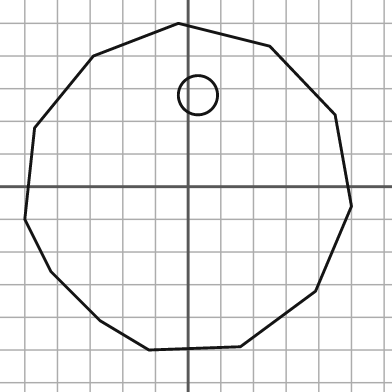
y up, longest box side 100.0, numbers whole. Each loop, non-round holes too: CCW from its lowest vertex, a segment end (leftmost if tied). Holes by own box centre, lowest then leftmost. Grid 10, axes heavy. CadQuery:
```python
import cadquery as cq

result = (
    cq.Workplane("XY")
    .moveTo(-12.0, -50.0)
    .lineTo(16.0, -49.0)
    .lineTo(39.0, -32.0)
    .lineTo(50.0, -6.0)
    .lineTo(45.0, 22.0)
    .lineTo(25.0, 43.0)
    .lineTo(-3.0, 50.0)
    .lineTo(-29.0, 40.0)
    .lineTo(-47.0, 18.0)
    .lineTo(-50.0, -10.0)
    .lineTo(-42.0, -26.0)
    .lineTo(-27.0, -41.0)
    .close()
    .moveTo(3.0, 28.0)
    .circle(6.0)
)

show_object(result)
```